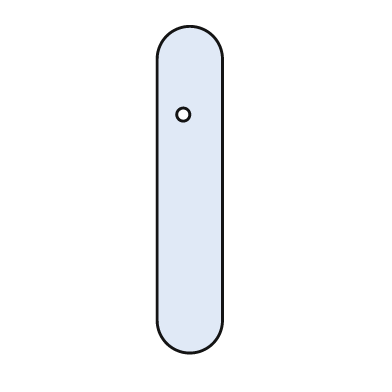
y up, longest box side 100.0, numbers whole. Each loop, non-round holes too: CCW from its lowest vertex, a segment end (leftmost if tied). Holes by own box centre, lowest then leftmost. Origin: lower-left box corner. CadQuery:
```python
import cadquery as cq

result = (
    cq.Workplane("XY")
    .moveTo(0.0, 10.0)
    .threePointArc((10.0, 0.0), (20.0, 10.0))
    .lineTo(20.0, 90.0)
    .threePointArc((10.0, 100.0), (0.0, 90.0))
    .close()
    .moveTo(8.0, 73.0)
    .circle(2.0)
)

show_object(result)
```